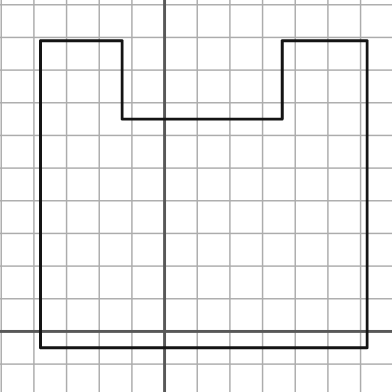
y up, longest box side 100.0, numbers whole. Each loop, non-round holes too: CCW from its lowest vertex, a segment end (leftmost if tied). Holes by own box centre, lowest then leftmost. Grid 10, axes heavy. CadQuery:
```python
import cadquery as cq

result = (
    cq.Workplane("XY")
    .moveTo(-38.0, -5.0)
    .lineTo(62.0, -5.0)
    .lineTo(62.0, 89.0)
    .lineTo(36.0, 89.0)
    .lineTo(36.0, 65.0)
    .lineTo(-13.0, 65.0)
    .lineTo(-13.0, 89.0)
    .lineTo(-38.0, 89.0)
    .close()
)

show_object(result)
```